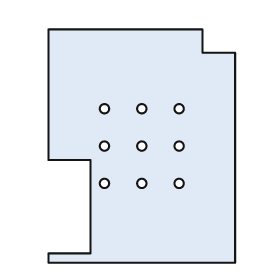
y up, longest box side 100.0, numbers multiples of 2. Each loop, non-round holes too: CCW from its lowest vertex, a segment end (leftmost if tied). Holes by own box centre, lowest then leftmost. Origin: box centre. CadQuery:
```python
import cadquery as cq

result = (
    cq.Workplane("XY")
    .moveTo(-40.0, -50.0)
    .lineTo(40.0, -50.0)
    .lineTo(40.0, 40.0)
    .lineTo(26.0, 40.0)
    .lineTo(26.0, 50.0)
    .lineTo(-40.0, 50.0)
    .lineTo(-40.0, -6.0)
    .lineTo(-22.0, -6.0)
    .lineTo(-22.0, -46.0)
    .lineTo(-40.0, -46.0)
    .close()
    .moveTo(-16.0, -16.0)
    .circle(2.0)
    .moveTo(0.0, -16.0)
    .circle(2.0)
    .moveTo(16.0, -16.0)
    .circle(2.0)
    .moveTo(-16.0, 0.0)
    .circle(2.0)
    .moveTo(0.0, 0.0)
    .circle(2.0)
    .moveTo(16.0, 0.0)
    .circle(2.0)
    .moveTo(-16.0, 16.0)
    .circle(2.0)
    .moveTo(0.0, 16.0)
    .circle(2.0)
    .moveTo(16.0, 16.0)
    .circle(2.0)
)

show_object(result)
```